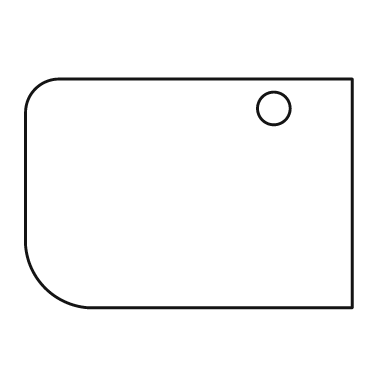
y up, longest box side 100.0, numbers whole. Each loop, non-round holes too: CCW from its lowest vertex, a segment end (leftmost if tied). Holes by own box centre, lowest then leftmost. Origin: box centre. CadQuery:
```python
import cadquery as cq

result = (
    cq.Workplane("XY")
    .moveTo(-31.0, -35.0)
    .lineTo(50.0, -35.0)
    .lineTo(50.0, 35.0)
    .lineTo(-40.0, 35.0)
    .threePointArc((-47.0, 32.0), (-50.0, 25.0))
    .lineTo(-50.0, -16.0)
    .threePointArc((-44.0, -29.0), (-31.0, -35.0))
    .close()
    .moveTo(26.0, 26.0)
    .circle(5.0)
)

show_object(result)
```